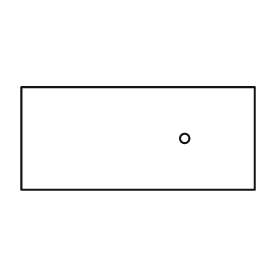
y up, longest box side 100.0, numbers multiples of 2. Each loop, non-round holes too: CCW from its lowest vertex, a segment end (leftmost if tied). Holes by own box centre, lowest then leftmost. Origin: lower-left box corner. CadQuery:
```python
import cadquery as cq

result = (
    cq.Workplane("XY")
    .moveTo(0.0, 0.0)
    .lineTo(100.0, 0.0)
    .lineTo(100.0, 44.0)
    .lineTo(0.0, 44.0)
    .close()
    .moveTo(70.0, 22.0)
    .circle(2.0)
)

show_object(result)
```